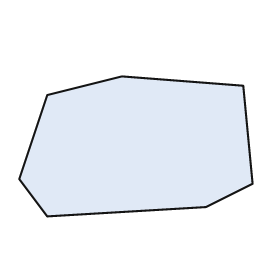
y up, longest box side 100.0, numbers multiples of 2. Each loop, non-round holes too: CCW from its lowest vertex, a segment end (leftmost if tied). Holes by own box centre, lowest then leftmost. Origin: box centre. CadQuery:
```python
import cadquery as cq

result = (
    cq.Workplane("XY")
    .moveTo(-38.0, -30.0)
    .lineTo(30.0, -26.0)
    .lineTo(50.0, -16.0)
    .lineTo(46.0, 26.0)
    .lineTo(-6.0, 30.0)
    .lineTo(-38.0, 22.0)
    .lineTo(-50.0, -14.0)
    .close()
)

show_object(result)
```